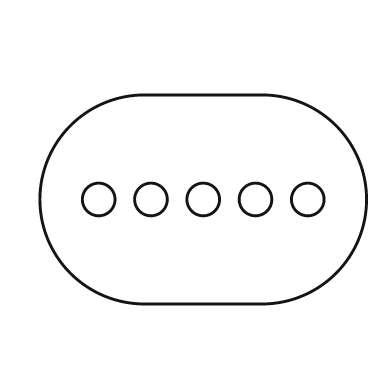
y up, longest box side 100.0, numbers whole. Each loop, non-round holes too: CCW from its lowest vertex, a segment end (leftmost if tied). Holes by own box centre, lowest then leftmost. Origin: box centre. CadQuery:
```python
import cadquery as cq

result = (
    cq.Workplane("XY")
    .moveTo(-18.0, -32.0)
    .lineTo(18.0, -32.0)
    .threePointArc((50.0, 0.0), (18.0, 32.0))
    .lineTo(-18.0, 32.0)
    .threePointArc((-50.0, 0.0), (-18.0, -32.0))
    .close()
    .moveTo(-32.0, 0.0)
    .circle(5.0)
    .moveTo(-16.0, 0.0)
    .circle(5.0)
    .moveTo(0.0, 0.0)
    .circle(5.0)
    .moveTo(16.0, 0.0)
    .circle(5.0)
    .moveTo(32.0, 0.0)
    .circle(5.0)
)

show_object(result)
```